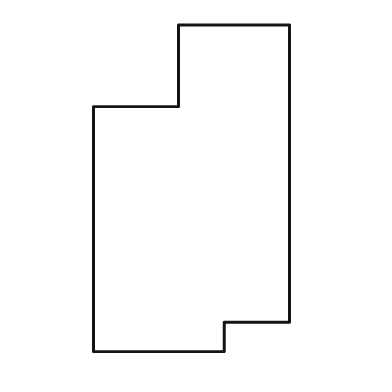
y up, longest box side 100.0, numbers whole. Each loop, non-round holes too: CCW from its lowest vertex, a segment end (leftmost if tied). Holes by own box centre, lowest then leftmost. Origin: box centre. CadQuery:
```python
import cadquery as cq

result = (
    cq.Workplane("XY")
    .moveTo(-30.0, -50.0)
    .lineTo(10.0, -50.0)
    .lineTo(10.0, -41.0)
    .lineTo(30.0, -41.0)
    .lineTo(30.0, 50.0)
    .lineTo(-4.0, 50.0)
    .lineTo(-4.0, 25.0)
    .lineTo(-30.0, 25.0)
    .close()
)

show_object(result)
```